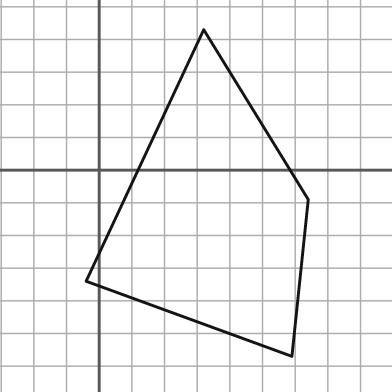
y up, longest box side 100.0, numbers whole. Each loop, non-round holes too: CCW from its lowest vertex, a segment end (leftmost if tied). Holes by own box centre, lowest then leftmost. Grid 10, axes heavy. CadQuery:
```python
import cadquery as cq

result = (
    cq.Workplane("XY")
    .moveTo(59.0, -57.0)
    .lineTo(64.0, -9.0)
    .lineTo(32.0, 43.0)
    .lineTo(-4.0, -34.0)
    .close()
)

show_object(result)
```